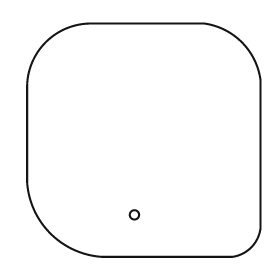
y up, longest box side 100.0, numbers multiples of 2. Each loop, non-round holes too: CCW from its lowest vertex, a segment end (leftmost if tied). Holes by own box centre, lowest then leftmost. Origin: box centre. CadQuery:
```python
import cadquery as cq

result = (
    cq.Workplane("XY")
    .moveTo(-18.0, -50.0)
    .lineTo(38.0, -50.0)
    .threePointArc((46.0, -46.0), (50.0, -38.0))
    .lineTo(50.0, 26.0)
    .threePointArc((42.0, 42.0), (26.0, 50.0))
    .lineTo(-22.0, 50.0)
    .threePointArc((-42.0, 42.0), (-50.0, 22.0))
    .lineTo(-50.0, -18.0)
    .threePointArc((-40.0, -40.0), (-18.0, -50.0))
    .close()
    .moveTo(-4.0, -32.0)
    .circle(2.0)
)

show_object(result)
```